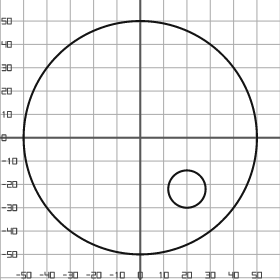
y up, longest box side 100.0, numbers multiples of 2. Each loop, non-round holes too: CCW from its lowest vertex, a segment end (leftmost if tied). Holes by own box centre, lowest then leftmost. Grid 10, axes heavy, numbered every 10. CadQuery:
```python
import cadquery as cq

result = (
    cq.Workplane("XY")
    .moveTo(0.0, 0.0)
    .circle(50.0)
    .moveTo(20.0, -22.0)
    .circle(8.0)
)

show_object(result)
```